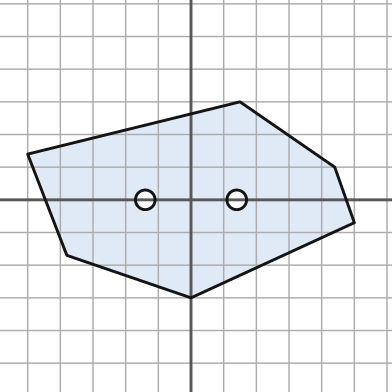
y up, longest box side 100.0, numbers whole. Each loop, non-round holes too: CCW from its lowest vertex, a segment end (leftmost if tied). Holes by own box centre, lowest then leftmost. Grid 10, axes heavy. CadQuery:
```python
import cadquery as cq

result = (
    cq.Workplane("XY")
    .moveTo(0.0, -30.0)
    .lineTo(50.0, -7.0)
    .lineTo(44.0, 10.0)
    .lineTo(15.0, 30.0)
    .lineTo(-50.0, 14.0)
    .lineTo(-38.0, -17.0)
    .close()
    .moveTo(-14.0, 0.0)
    .circle(3.0)
    .moveTo(14.0, 0.0)
    .circle(3.0)
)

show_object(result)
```